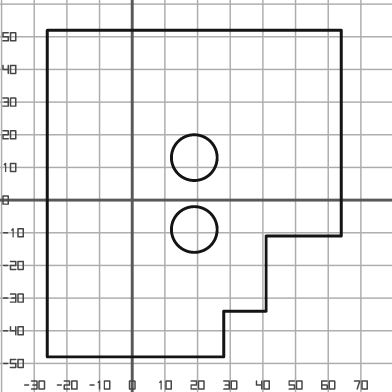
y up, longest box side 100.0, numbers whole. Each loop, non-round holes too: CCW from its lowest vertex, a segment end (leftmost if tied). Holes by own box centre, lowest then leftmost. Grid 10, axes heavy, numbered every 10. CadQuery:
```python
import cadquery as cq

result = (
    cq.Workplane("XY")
    .moveTo(-26.0, -48.0)
    .lineTo(28.0, -48.0)
    .lineTo(28.0, -34.0)
    .lineTo(41.0, -34.0)
    .lineTo(41.0, -11.0)
    .lineTo(64.0, -11.0)
    .lineTo(64.0, 52.0)
    .lineTo(-26.0, 52.0)
    .close()
    .moveTo(19.0, -9.0)
    .circle(7.0)
    .moveTo(19.0, 13.0)
    .circle(7.0)
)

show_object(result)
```